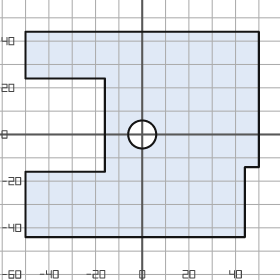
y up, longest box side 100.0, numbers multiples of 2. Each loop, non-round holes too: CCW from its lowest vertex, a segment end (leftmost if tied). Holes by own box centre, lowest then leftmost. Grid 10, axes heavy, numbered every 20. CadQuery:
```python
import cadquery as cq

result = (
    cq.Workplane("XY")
    .moveTo(-50.0, -44.0)
    .lineTo(44.0, -44.0)
    .lineTo(44.0, -14.0)
    .lineTo(50.0, -14.0)
    .lineTo(50.0, 44.0)
    .lineTo(-50.0, 44.0)
    .lineTo(-50.0, 24.0)
    .lineTo(-16.0, 24.0)
    .lineTo(-16.0, -16.0)
    .lineTo(-50.0, -16.0)
    .close()
    .moveTo(0.0, 0.0)
    .circle(6.0)
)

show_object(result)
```